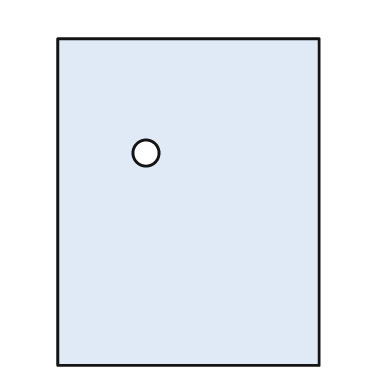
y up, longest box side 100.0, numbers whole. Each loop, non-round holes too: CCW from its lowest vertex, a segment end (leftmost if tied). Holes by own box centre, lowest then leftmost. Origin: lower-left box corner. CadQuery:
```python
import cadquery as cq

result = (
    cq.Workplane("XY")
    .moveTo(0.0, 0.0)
    .lineTo(80.0, 0.0)
    .lineTo(80.0, 100.0)
    .lineTo(0.0, 100.0)
    .close()
    .moveTo(27.0, 65.0)
    .circle(4.0)
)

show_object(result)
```